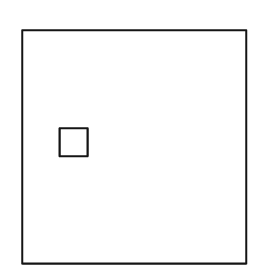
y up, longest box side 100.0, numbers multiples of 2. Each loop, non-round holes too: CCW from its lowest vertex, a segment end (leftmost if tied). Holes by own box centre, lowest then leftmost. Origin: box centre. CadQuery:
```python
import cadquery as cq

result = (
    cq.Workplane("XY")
    .moveTo(-48.0, -50.0)
    .lineTo(48.0, -50.0)
    .lineTo(48.0, 50.0)
    .lineTo(-48.0, 50.0)
    .close()
    .moveTo(-32.0, -4.0)
    .lineTo(-20.0, -4.0)
    .lineTo(-20.0, 8.0)
    .lineTo(-32.0, 8.0)
    .close()
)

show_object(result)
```